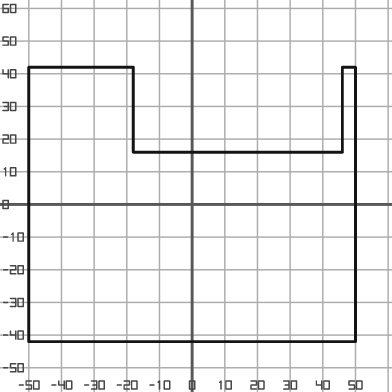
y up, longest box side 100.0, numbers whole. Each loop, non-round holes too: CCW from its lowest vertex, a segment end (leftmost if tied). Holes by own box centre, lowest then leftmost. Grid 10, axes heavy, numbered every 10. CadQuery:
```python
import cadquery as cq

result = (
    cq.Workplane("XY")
    .moveTo(-50.0, -42.0)
    .lineTo(50.0, -42.0)
    .lineTo(50.0, 42.0)
    .lineTo(46.0, 42.0)
    .lineTo(46.0, 16.0)
    .lineTo(-18.0, 16.0)
    .lineTo(-18.0, 42.0)
    .lineTo(-50.0, 42.0)
    .close()
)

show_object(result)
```